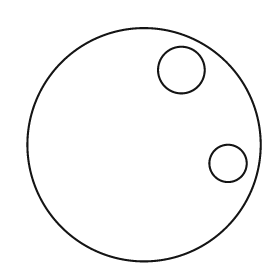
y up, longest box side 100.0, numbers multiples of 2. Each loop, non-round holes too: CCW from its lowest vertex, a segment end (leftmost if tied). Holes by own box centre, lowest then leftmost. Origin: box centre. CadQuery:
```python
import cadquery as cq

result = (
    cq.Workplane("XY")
    .moveTo(0.0, 0.0)
    .circle(50.0)
    .moveTo(36.0, -8.0)
    .circle(8.0)
    .moveTo(16.0, 32.0)
    .circle(10.0)
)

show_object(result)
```